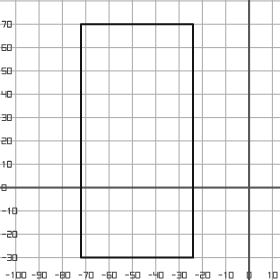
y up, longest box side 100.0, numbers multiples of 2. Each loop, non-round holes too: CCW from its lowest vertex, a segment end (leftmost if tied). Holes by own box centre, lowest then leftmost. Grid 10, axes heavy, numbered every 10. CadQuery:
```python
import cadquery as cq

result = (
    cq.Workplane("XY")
    .moveTo(-72.0, -30.0)
    .lineTo(-24.0, -30.0)
    .lineTo(-24.0, 70.0)
    .lineTo(-72.0, 70.0)
    .close()
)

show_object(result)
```